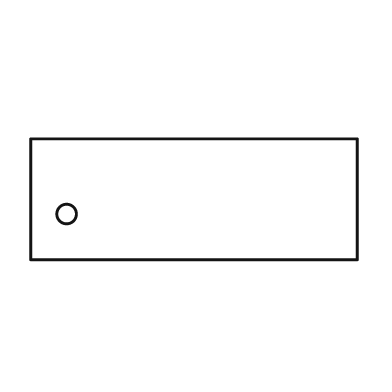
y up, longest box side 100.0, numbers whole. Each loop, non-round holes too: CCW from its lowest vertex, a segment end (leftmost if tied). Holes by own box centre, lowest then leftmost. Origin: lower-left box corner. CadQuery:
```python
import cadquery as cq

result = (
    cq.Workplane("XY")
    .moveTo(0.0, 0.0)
    .lineTo(100.0, 0.0)
    .lineTo(100.0, 37.0)
    .lineTo(0.0, 37.0)
    .close()
    .moveTo(11.0, 14.0)
    .circle(3.0)
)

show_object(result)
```